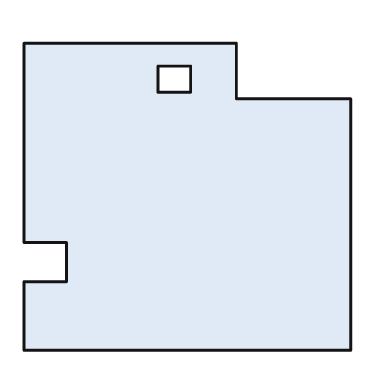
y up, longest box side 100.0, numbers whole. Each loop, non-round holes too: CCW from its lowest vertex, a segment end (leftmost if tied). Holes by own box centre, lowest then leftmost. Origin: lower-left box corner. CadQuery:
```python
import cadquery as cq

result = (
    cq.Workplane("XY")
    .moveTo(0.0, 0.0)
    .lineTo(100.0, 0.0)
    .lineTo(100.0, 77.0)
    .lineTo(65.0, 77.0)
    .lineTo(65.0, 94.0)
    .lineTo(0.0, 94.0)
    .lineTo(0.0, 33.0)
    .lineTo(13.0, 33.0)
    .lineTo(13.0, 21.0)
    .lineTo(0.0, 21.0)
    .close()
    .moveTo(41.0, 79.0)
    .lineTo(51.0, 79.0)
    .lineTo(51.0, 87.0)
    .lineTo(41.0, 87.0)
    .close()
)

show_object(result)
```